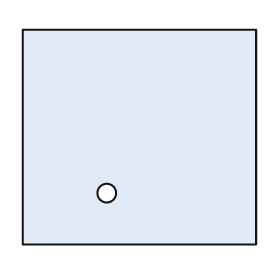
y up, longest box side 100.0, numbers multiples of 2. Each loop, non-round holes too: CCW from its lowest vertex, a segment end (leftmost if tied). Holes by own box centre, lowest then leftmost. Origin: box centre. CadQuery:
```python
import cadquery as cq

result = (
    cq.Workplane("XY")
    .moveTo(-50.0, -46.0)
    .lineTo(50.0, -46.0)
    .lineTo(50.0, 46.0)
    .lineTo(-50.0, 46.0)
    .close()
    .moveTo(-14.0, -24.0)
    .circle(4.0)
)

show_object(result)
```